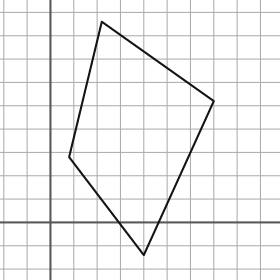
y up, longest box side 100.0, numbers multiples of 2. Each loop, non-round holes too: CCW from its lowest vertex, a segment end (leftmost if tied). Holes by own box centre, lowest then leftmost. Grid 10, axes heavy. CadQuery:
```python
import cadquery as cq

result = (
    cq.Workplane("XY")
    .moveTo(40.0, -14.0)
    .lineTo(70.0, 52.0)
    .lineTo(22.0, 86.0)
    .lineTo(8.0, 28.0)
    .close()
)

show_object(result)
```